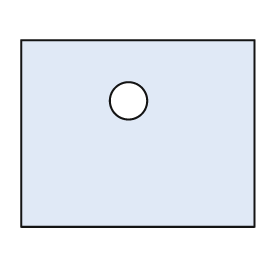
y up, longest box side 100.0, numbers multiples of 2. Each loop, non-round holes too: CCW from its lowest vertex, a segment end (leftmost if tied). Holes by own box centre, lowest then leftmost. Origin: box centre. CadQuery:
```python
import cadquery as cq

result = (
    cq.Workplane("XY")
    .moveTo(-50.0, -40.0)
    .lineTo(50.0, -40.0)
    .lineTo(50.0, 40.0)
    .lineTo(-50.0, 40.0)
    .close()
    .moveTo(-4.0, 14.0)
    .circle(8.0)
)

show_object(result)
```